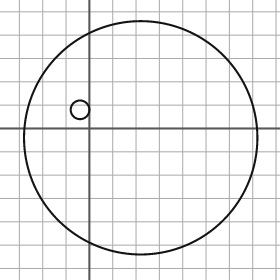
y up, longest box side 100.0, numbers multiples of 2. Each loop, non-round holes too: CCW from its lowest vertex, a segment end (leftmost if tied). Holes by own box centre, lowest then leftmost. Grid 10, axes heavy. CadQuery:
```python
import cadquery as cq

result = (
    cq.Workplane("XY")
    .moveTo(22.0, -4.0)
    .circle(50.0)
    .moveTo(-4.0, 8.0)
    .circle(4.0)
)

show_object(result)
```